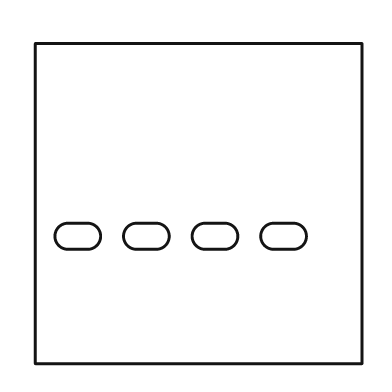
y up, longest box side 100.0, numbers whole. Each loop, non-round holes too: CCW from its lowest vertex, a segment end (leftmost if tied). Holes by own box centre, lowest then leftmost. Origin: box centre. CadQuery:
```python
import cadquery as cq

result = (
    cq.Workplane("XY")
    .moveTo(-50.0, -49.0)
    .lineTo(50.0, -49.0)
    .lineTo(50.0, 49.0)
    .lineTo(-50.0, 49.0)
    .close()
    .moveTo(-40.0, -14.0)
    .lineTo(-34.0, -14.0)
    .threePointArc((-30.0, -10.0), (-34.0, -6.0))
    .lineTo(-40.0, -6.0)
    .threePointArc((-44.0, -10.0), (-40.0, -14.0))
    .close()
    .moveTo(-19.0, -14.0)
    .lineTo(-13.0, -14.0)
    .threePointArc((-9.0, -10.0), (-13.0, -6.0))
    .lineTo(-19.0, -6.0)
    .threePointArc((-23.0, -10.0), (-19.0, -14.0))
    .close()
    .moveTo(2.0, -14.0)
    .lineTo(8.0, -14.0)
    .threePointArc((12.0, -10.0), (8.0, -6.0))
    .lineTo(2.0, -6.0)
    .threePointArc((-2.0, -10.0), (2.0, -14.0))
    .close()
    .moveTo(23.0, -14.0)
    .lineTo(29.0, -14.0)
    .threePointArc((33.0, -10.0), (29.0, -6.0))
    .lineTo(23.0, -6.0)
    .threePointArc((19.0, -10.0), (23.0, -14.0))
    .close()
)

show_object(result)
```